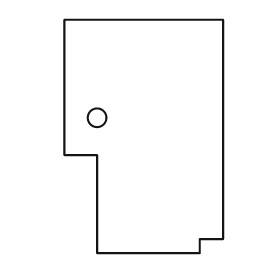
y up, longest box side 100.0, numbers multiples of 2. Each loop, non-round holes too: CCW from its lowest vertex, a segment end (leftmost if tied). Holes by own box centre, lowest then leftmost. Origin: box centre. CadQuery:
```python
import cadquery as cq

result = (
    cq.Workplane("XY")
    .moveTo(-20.0, -50.0)
    .lineTo(24.0, -50.0)
    .lineTo(24.0, -44.0)
    .lineTo(34.0, -44.0)
    .lineTo(34.0, 50.0)
    .lineTo(-34.0, 50.0)
    .lineTo(-34.0, -8.0)
    .lineTo(-20.0, -8.0)
    .close()
    .moveTo(-20.0, 8.0)
    .circle(4.0)
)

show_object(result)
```